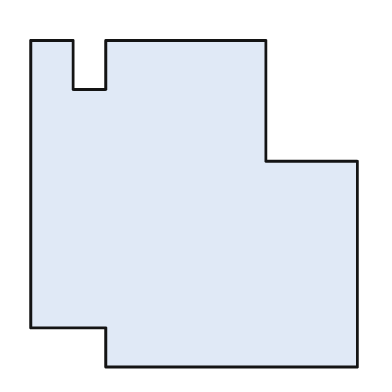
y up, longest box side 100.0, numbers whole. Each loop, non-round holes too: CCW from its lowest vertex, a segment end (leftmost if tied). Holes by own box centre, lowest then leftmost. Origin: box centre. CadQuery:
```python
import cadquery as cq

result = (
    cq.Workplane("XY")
    .moveTo(-27.0, -50.0)
    .lineTo(50.0, -50.0)
    .lineTo(50.0, 13.0)
    .lineTo(22.0, 13.0)
    .lineTo(22.0, 50.0)
    .lineTo(-27.0, 50.0)
    .lineTo(-27.0, 35.0)
    .lineTo(-37.0, 35.0)
    .lineTo(-37.0, 50.0)
    .lineTo(-50.0, 50.0)
    .lineTo(-50.0, -38.0)
    .lineTo(-27.0, -38.0)
    .close()
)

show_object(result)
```